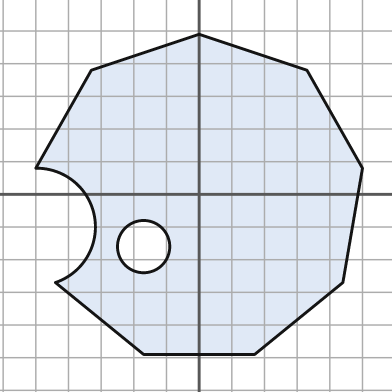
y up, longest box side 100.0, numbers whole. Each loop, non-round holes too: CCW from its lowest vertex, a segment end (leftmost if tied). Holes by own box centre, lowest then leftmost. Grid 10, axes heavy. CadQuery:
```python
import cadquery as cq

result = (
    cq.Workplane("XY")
    .moveTo(-17.0, -49.0)
    .lineTo(17.0, -49.0)
    .lineTo(44.0, -27.0)
    .lineTo(50.0, 8.0)
    .lineTo(33.0, 38.0)
    .lineTo(0.0, 49.0)
    .lineTo(-33.0, 38.0)
    .lineTo(-50.0, 8.0)
    .threePointArc((-32.0, -7.0), (-44.0, -27.0))
    .close()
    .moveTo(-17.0, -16.0)
    .circle(8.0)
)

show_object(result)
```